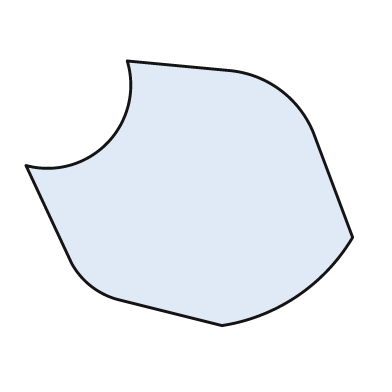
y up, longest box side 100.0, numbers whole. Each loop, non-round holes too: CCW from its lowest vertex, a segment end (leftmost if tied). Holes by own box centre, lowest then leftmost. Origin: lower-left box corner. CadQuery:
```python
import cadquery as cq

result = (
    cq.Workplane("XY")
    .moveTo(60.0, 0.0)
    .threePointArc((83.0, 9.0), (100.0, 27.0))
    .lineTo(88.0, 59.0)
    .threePointArc((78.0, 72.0), (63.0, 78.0))
    .lineTo(31.0, 81.0)
    .threePointArc((25.0, 56.0), (0.0, 49.0))
    .lineTo(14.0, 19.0)
    .threePointArc((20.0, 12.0), (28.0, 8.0))
    .close()
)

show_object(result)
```